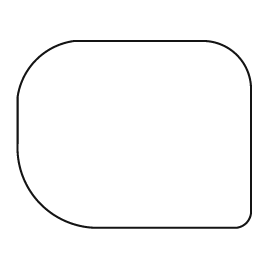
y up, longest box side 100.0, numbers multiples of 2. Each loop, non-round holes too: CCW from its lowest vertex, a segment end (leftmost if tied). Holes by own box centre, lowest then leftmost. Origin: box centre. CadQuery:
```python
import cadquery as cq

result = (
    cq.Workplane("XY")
    .moveTo(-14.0, -40.0)
    .lineTo(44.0, -40.0)
    .threePointArc((48.0, -38.0), (50.0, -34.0))
    .lineTo(50.0, 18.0)
    .threePointArc((44.0, 34.0), (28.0, 40.0))
    .lineTo(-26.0, 40.0)
    .threePointArc((-42.0, 32.0), (-50.0, 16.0))
    .lineTo(-50.0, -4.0)
    .threePointArc((-40.0, -30.0), (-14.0, -40.0))
    .close()
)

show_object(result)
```